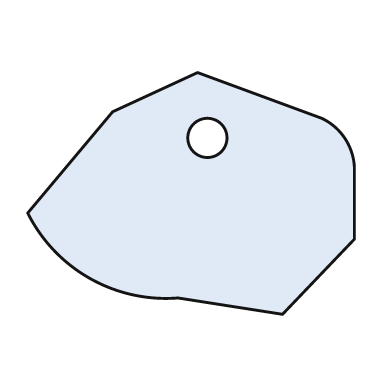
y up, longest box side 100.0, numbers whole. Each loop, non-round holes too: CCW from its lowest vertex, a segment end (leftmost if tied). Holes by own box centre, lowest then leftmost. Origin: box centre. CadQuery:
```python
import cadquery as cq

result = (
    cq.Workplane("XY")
    .moveTo(28.0, -37.0)
    .lineTo(50.0, -14.0)
    .lineTo(50.0, 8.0)
    .threePointArc((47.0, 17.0), (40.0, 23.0))
    .lineTo(2.0, 37.0)
    .lineTo(-24.0, 25.0)
    .lineTo(-50.0, -6.0)
    .threePointArc((-31.0, -26.0), (-4.0, -32.0))
    .close()
    .moveTo(5.0, 17.0)
    .circle(6.0)
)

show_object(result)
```